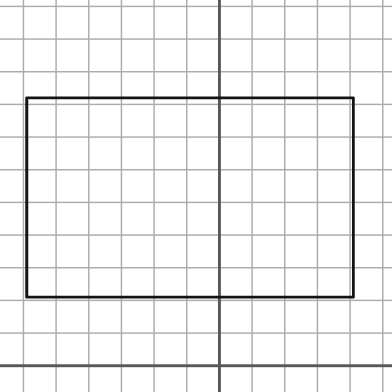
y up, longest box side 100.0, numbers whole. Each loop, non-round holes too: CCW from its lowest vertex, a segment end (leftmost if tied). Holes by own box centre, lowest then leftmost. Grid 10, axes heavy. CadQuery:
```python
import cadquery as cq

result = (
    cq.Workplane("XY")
    .moveTo(-59.0, 21.0)
    .lineTo(41.0, 21.0)
    .lineTo(41.0, 82.0)
    .lineTo(-59.0, 82.0)
    .close()
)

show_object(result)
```